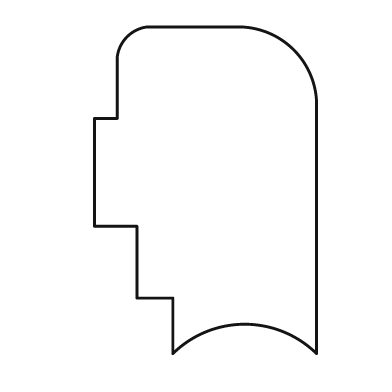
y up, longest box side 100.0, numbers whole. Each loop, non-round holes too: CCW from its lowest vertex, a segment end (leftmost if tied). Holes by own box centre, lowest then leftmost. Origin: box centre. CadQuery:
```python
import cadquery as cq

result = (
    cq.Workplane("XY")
    .moveTo(-10.0, -50.0)
    .threePointArc((12.0, -41.0), (34.0, -50.0))
    .lineTo(34.0, 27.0)
    .threePointArc((27.0, 43.0), (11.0, 50.0))
    .lineTo(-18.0, 50.0)
    .threePointArc((-24.0, 47.0), (-27.0, 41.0))
    .lineTo(-27.0, 22.0)
    .lineTo(-34.0, 22.0)
    .lineTo(-34.0, -11.0)
    .lineTo(-21.0, -11.0)
    .lineTo(-21.0, -33.0)
    .lineTo(-10.0, -33.0)
    .close()
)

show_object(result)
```